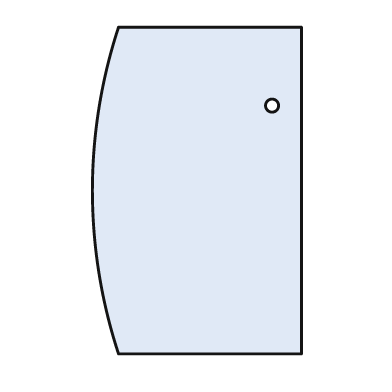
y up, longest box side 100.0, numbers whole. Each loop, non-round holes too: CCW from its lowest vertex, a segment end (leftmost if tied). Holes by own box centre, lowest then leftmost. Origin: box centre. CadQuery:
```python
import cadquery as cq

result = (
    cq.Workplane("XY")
    .moveTo(-24.0, -50.0)
    .lineTo(32.0, -50.0)
    .lineTo(32.0, 50.0)
    .lineTo(-24.0, 50.0)
    .threePointArc((-32.0, 0.0), (-24.0, -50.0))
    .close()
    .moveTo(23.0, 26.0)
    .circle(2.0)
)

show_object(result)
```